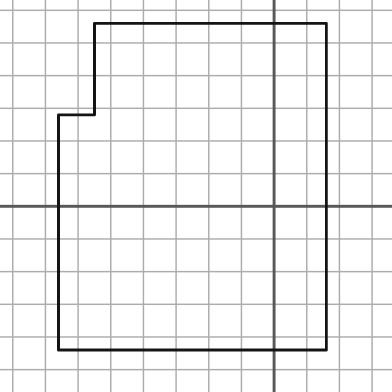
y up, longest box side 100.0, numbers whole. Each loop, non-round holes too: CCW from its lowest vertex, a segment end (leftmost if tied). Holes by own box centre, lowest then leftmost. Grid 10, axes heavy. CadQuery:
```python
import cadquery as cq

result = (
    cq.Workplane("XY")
    .moveTo(-66.0, -44.0)
    .lineTo(16.0, -44.0)
    .lineTo(16.0, 56.0)
    .lineTo(-55.0, 56.0)
    .lineTo(-55.0, 28.0)
    .lineTo(-66.0, 28.0)
    .close()
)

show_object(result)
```